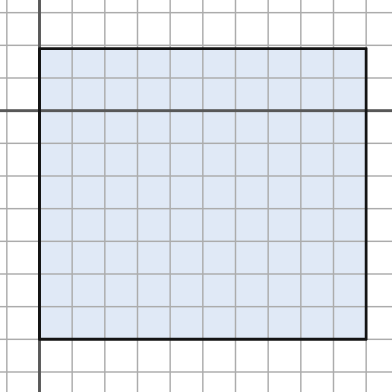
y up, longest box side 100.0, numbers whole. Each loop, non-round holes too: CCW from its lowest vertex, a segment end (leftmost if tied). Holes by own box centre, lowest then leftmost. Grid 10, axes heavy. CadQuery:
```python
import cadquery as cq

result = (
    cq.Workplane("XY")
    .moveTo(0.0, -70.0)
    .lineTo(100.0, -70.0)
    .lineTo(100.0, 19.0)
    .lineTo(0.0, 19.0)
    .close()
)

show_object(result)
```